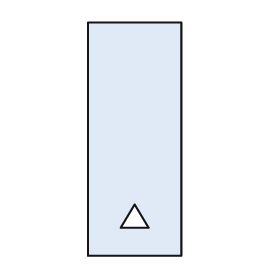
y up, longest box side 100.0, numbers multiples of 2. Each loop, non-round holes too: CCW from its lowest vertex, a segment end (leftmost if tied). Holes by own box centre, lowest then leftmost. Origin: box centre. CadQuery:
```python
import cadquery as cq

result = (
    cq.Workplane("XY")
    .moveTo(-20.0, -50.0)
    .lineTo(20.0, -50.0)
    .lineTo(20.0, 50.0)
    .lineTo(-20.0, 50.0)
    .close()
    .moveTo(-6.0, -38.0)
    .lineTo(6.0, -38.0)
    .lineTo(0.0, -28.0)
    .close()
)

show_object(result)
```